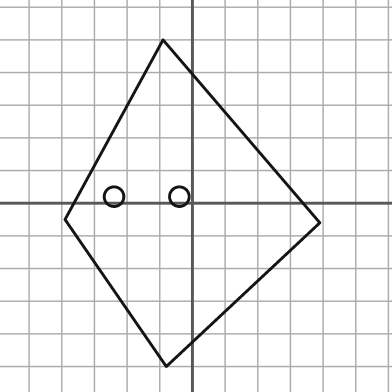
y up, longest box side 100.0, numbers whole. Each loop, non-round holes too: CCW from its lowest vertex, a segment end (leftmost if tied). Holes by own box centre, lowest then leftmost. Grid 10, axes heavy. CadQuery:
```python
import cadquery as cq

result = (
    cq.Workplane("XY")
    .moveTo(-8.0, -50.0)
    .lineTo(39.0, -6.0)
    .lineTo(-9.0, 50.0)
    .lineTo(-39.0, -5.0)
    .close()
    .moveTo(-24.0, 2.0)
    .circle(3.0)
    .moveTo(-4.0, 2.0)
    .circle(3.0)
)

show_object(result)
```